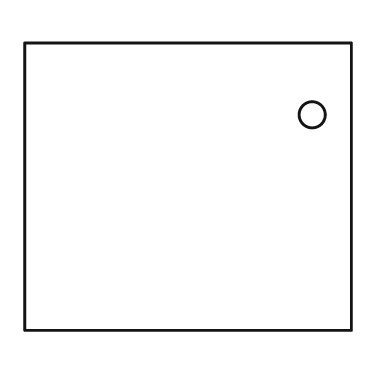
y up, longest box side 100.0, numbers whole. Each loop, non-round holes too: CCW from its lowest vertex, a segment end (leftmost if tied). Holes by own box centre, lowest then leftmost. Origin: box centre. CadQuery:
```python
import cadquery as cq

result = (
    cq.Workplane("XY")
    .moveTo(-50.0, -44.0)
    .lineTo(50.0, -44.0)
    .lineTo(50.0, 44.0)
    .lineTo(-50.0, 44.0)
    .close()
    .moveTo(38.0, 22.0)
    .circle(4.0)
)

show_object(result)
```